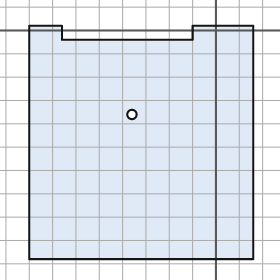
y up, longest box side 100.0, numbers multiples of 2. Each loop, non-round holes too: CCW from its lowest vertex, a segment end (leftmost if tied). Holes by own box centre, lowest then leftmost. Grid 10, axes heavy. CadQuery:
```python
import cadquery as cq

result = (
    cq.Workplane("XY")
    .moveTo(-80.0, -98.0)
    .lineTo(16.0, -98.0)
    .lineTo(16.0, 2.0)
    .lineTo(-10.0, 2.0)
    .lineTo(-10.0, -4.0)
    .lineTo(-66.0, -4.0)
    .lineTo(-66.0, 2.0)
    .lineTo(-80.0, 2.0)
    .close()
    .moveTo(-36.0, -36.0)
    .circle(2.0)
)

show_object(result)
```